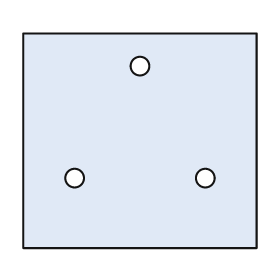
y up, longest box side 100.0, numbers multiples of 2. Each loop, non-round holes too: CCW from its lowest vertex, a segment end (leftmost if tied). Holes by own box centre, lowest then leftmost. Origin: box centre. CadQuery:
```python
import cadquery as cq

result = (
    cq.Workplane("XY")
    .moveTo(-50.0, -46.0)
    .lineTo(50.0, -46.0)
    .lineTo(50.0, 46.0)
    .lineTo(-50.0, 46.0)
    .close()
    .moveTo(-28.0, -16.0)
    .circle(4.0)
    .moveTo(28.0, -16.0)
    .circle(4.0)
    .moveTo(0.0, 32.0)
    .circle(4.0)
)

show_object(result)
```